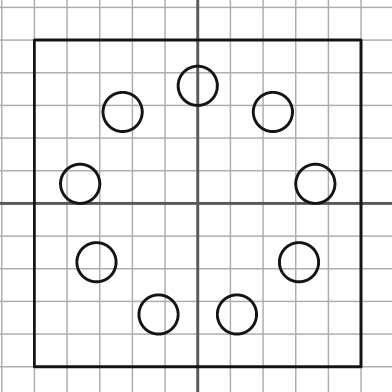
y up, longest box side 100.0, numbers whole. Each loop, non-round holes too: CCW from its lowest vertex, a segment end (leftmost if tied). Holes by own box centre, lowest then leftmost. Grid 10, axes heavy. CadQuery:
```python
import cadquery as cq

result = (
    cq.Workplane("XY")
    .moveTo(-50.0, -50.0)
    .lineTo(50.0, -50.0)
    .lineTo(50.0, 50.0)
    .lineTo(-50.0, 50.0)
    .close()
    .moveTo(-12.0, -34.0)
    .circle(6.0)
    .moveTo(12.0, -34.0)
    .circle(6.0)
    .moveTo(-31.0, -18.0)
    .circle(6.0)
    .moveTo(31.0, -18.0)
    .circle(6.0)
    .moveTo(-36.0, 6.0)
    .circle(6.0)
    .moveTo(36.0, 6.0)
    .circle(6.0)
    .moveTo(-23.0, 28.0)
    .circle(6.0)
    .moveTo(23.0, 28.0)
    .circle(6.0)
    .moveTo(0.0, 36.0)
    .circle(6.0)
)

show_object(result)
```